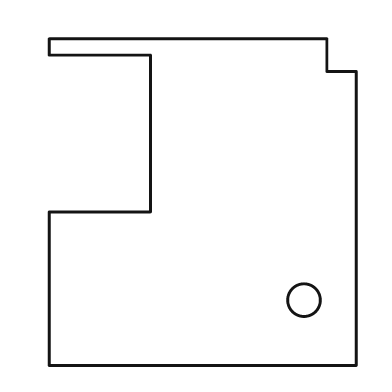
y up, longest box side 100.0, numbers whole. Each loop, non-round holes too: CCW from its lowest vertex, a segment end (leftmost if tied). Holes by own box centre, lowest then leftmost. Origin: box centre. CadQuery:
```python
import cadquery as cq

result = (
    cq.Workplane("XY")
    .moveTo(-47.0, -50.0)
    .lineTo(47.0, -50.0)
    .lineTo(47.0, 40.0)
    .lineTo(38.0, 40.0)
    .lineTo(38.0, 50.0)
    .lineTo(-47.0, 50.0)
    .lineTo(-47.0, 45.0)
    .lineTo(-16.0, 45.0)
    .lineTo(-16.0, -3.0)
    .lineTo(-47.0, -3.0)
    .close()
    .moveTo(31.0, -30.0)
    .circle(5.0)
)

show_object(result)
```